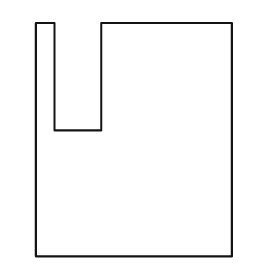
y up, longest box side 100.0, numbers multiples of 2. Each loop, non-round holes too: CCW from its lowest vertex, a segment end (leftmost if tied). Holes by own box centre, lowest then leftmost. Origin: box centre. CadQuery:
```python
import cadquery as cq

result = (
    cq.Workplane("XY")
    .moveTo(-42.0, -50.0)
    .lineTo(42.0, -50.0)
    .lineTo(42.0, 50.0)
    .lineTo(-14.0, 50.0)
    .lineTo(-14.0, 4.0)
    .lineTo(-34.0, 4.0)
    .lineTo(-34.0, 50.0)
    .lineTo(-42.0, 50.0)
    .close()
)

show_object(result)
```